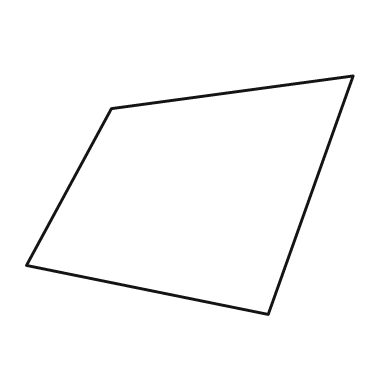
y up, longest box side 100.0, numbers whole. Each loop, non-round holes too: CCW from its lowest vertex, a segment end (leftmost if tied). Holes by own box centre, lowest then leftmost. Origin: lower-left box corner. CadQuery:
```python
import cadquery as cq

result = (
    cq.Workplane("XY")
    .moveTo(74.0, 0.0)
    .lineTo(100.0, 73.0)
    .lineTo(26.0, 63.0)
    .lineTo(0.0, 15.0)
    .close()
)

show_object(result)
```